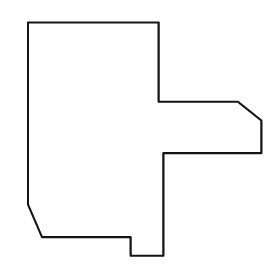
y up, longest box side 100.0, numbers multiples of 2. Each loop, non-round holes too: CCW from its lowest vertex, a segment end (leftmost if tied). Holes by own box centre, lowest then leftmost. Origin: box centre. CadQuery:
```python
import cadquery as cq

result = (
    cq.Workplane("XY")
    .moveTo(-6.0, -50.0)
    .lineTo(8.0, -50.0)
    .lineTo(8.0, -6.0)
    .lineTo(50.0, -6.0)
    .lineTo(50.0, 8.0)
    .lineTo(40.0, 16.0)
    .lineTo(6.0, 16.0)
    .lineTo(6.0, 50.0)
    .lineTo(-50.0, 50.0)
    .lineTo(-50.0, -28.0)
    .lineTo(-44.0, -42.0)
    .lineTo(-6.0, -42.0)
    .close()
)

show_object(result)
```